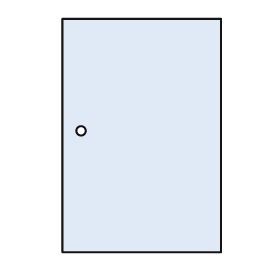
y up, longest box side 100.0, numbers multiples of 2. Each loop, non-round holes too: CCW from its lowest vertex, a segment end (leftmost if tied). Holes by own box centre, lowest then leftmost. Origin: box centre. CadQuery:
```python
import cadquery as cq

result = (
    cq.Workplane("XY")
    .moveTo(-34.0, -50.0)
    .lineTo(34.0, -50.0)
    .lineTo(34.0, 50.0)
    .lineTo(-34.0, 50.0)
    .close()
    .moveTo(-26.0, 2.0)
    .circle(2.0)
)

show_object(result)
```